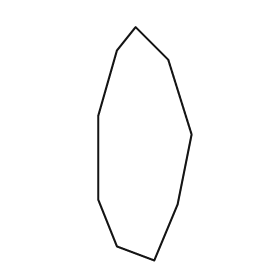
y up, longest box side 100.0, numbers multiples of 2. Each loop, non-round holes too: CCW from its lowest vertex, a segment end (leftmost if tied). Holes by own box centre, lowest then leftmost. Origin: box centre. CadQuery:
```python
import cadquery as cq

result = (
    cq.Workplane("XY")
    .moveTo(4.0, -50.0)
    .lineTo(14.0, -26.0)
    .lineTo(20.0, 4.0)
    .lineTo(10.0, 36.0)
    .lineTo(-4.0, 50.0)
    .lineTo(-12.0, 40.0)
    .lineTo(-20.0, 12.0)
    .lineTo(-20.0, -24.0)
    .lineTo(-12.0, -44.0)
    .close()
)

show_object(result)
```